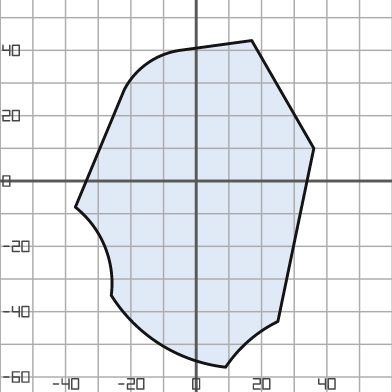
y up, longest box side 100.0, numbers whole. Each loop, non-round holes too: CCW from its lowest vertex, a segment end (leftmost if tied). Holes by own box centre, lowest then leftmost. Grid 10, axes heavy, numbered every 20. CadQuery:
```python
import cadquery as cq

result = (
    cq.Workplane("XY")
    .moveTo(9.0, -57.0)
    .threePointArc((16.0, -49.0), (25.0, -43.0))
    .lineTo(36.0, 10.0)
    .lineTo(17.0, 43.0)
    .lineTo(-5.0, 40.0)
    .threePointArc((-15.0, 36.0), (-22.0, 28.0))
    .lineTo(-37.0, -8.0)
    .threePointArc((-28.0, -20.0), (-26.0, -35.0))
    .threePointArc((-11.0, -50.0), (9.0, -57.0))
    .close()
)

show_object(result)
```